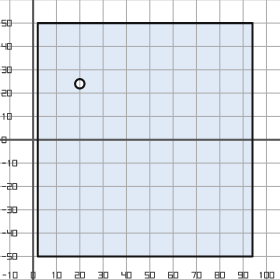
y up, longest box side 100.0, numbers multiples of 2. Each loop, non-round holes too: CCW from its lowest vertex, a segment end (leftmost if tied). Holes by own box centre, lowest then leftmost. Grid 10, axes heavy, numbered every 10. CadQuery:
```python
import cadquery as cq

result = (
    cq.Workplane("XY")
    .moveTo(2.0, -50.0)
    .lineTo(94.0, -50.0)
    .lineTo(94.0, 50.0)
    .lineTo(2.0, 50.0)
    .close()
    .moveTo(20.0, 24.0)
    .circle(2.0)
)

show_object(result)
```